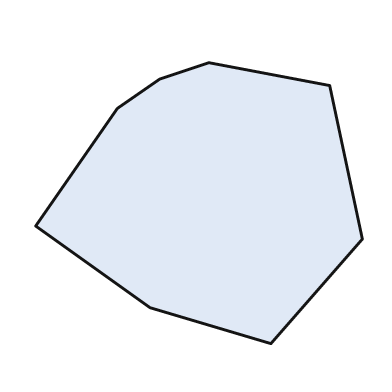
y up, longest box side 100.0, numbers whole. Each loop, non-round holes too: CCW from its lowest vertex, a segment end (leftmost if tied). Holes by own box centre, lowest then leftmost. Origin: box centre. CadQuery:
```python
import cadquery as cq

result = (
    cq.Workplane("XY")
    .moveTo(22.0, -43.0)
    .lineTo(50.0, -11.0)
    .lineTo(40.0, 36.0)
    .lineTo(3.0, 43.0)
    .lineTo(-12.0, 38.0)
    .lineTo(-25.0, 29.0)
    .lineTo(-50.0, -7.0)
    .lineTo(-15.0, -32.0)
    .close()
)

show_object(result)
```